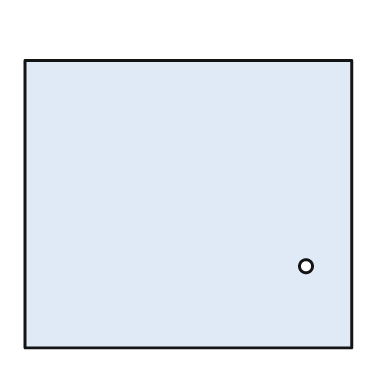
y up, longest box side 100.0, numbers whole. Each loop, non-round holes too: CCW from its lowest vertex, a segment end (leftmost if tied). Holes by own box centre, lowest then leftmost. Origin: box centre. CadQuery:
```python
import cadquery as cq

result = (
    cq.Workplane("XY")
    .moveTo(-50.0, -44.0)
    .lineTo(50.0, -44.0)
    .lineTo(50.0, 44.0)
    .lineTo(-50.0, 44.0)
    .close()
    .moveTo(36.0, -19.0)
    .circle(2.0)
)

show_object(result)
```